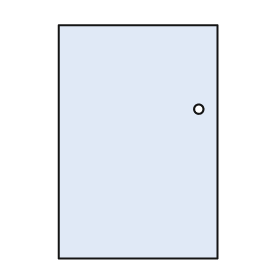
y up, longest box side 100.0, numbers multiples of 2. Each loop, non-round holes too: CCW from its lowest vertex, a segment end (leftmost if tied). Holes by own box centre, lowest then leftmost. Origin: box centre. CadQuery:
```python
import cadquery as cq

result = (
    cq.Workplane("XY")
    .moveTo(-34.0, -50.0)
    .lineTo(34.0, -50.0)
    .lineTo(34.0, 50.0)
    .lineTo(-34.0, 50.0)
    .close()
    .moveTo(26.0, 14.0)
    .circle(2.0)
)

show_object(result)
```